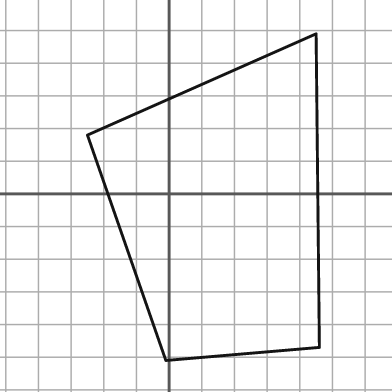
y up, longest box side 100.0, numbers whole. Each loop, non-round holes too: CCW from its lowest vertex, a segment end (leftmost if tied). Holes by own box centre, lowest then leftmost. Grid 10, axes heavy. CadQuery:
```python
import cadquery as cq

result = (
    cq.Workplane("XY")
    .moveTo(-1.0, -51.0)
    .lineTo(46.0, -47.0)
    .lineTo(45.0, 49.0)
    .lineTo(-25.0, 18.0)
    .close()
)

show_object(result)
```